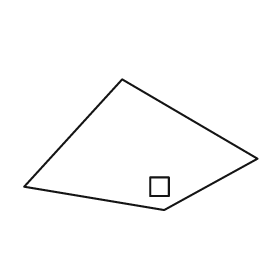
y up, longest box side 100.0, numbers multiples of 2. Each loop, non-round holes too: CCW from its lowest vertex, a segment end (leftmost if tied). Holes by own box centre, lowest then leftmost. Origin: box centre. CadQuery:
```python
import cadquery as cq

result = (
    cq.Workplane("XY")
    .moveTo(10.0, -28.0)
    .lineTo(50.0, -6.0)
    .lineTo(-8.0, 28.0)
    .lineTo(-50.0, -18.0)
    .close()
    .moveTo(4.0, -22.0)
    .lineTo(12.0, -22.0)
    .lineTo(12.0, -14.0)
    .lineTo(4.0, -14.0)
    .close()
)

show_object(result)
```